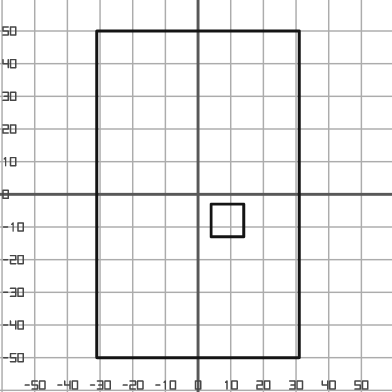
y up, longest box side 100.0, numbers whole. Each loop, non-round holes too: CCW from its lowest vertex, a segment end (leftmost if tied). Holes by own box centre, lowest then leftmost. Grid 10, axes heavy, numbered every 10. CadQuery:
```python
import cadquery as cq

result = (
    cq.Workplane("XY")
    .moveTo(-31.0, -50.0)
    .lineTo(31.0, -50.0)
    .lineTo(31.0, 50.0)
    .lineTo(-31.0, 50.0)
    .close()
    .moveTo(4.0, -13.0)
    .lineTo(14.0, -13.0)
    .lineTo(14.0, -3.0)
    .lineTo(4.0, -3.0)
    .close()
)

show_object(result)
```